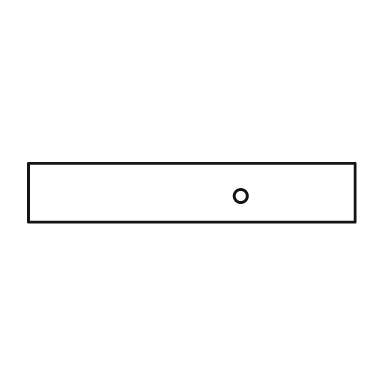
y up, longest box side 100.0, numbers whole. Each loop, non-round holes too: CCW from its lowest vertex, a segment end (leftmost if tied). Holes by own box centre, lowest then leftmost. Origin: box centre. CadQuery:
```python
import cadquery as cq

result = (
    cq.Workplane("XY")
    .moveTo(-50.0, -9.0)
    .lineTo(50.0, -9.0)
    .lineTo(50.0, 9.0)
    .lineTo(-50.0, 9.0)
    .close()
    .moveTo(15.0, -1.0)
    .circle(2.0)
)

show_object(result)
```